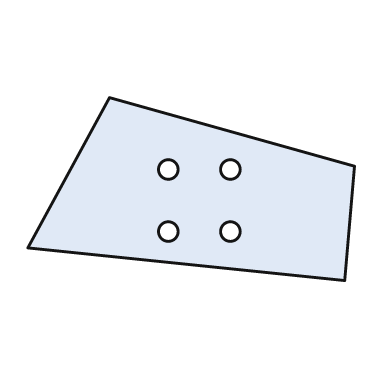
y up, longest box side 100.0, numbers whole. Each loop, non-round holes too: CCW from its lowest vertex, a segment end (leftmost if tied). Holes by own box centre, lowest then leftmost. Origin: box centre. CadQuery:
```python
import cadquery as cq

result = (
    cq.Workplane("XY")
    .moveTo(47.0, -28.0)
    .lineTo(50.0, 7.0)
    .lineTo(-25.0, 28.0)
    .lineTo(-50.0, -18.0)
    .close()
    .moveTo(-7.0, -13.0)
    .circle(3.0)
    .moveTo(12.0, -13.0)
    .circle(3.0)
    .moveTo(-7.0, 6.0)
    .circle(3.0)
    .moveTo(12.0, 6.0)
    .circle(3.0)
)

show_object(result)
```